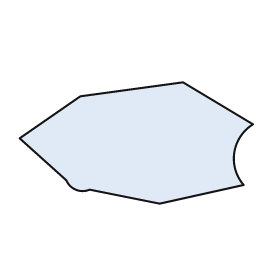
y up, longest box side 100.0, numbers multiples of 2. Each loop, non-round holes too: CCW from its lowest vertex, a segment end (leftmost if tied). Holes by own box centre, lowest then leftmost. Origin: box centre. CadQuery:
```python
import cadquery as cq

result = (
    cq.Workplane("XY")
    .moveTo(10.0, -26.0)
    .lineTo(46.0, -18.0)
    .threePointArc((42.0, -4.0), (50.0, 8.0))
    .lineTo(20.0, 26.0)
    .lineTo(-24.0, 20.0)
    .lineTo(-50.0, 2.0)
    .lineTo(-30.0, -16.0)
    .threePointArc((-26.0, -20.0), (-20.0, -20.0))
    .close()
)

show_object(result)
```